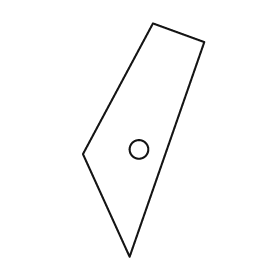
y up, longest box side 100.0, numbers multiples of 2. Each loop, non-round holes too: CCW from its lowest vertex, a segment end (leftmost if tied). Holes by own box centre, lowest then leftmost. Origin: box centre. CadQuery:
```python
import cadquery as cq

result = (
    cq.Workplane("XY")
    .moveTo(-6.0, -50.0)
    .lineTo(26.0, 42.0)
    .lineTo(4.0, 50.0)
    .lineTo(-26.0, -6.0)
    .close()
    .moveTo(-2.0, -4.0)
    .circle(4.0)
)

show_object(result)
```